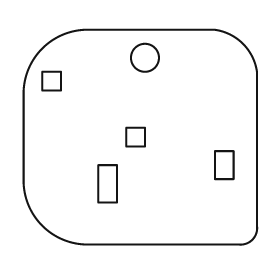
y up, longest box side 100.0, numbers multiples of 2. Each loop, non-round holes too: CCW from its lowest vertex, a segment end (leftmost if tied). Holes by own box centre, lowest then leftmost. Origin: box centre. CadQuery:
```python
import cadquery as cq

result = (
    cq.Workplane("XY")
    .moveTo(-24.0, -46.0)
    .lineTo(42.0, -46.0)
    .threePointArc((48.0, -44.0), (50.0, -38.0))
    .lineTo(50.0, 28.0)
    .threePointArc((44.0, 40.0), (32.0, 46.0))
    .lineTo(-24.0, 46.0)
    .threePointArc((-42.0, 38.0), (-50.0, 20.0))
    .lineTo(-50.0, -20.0)
    .threePointArc((-42.0, -38.0), (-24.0, -46.0))
    .close()
    .moveTo(-18.0, -28.0)
    .lineTo(-10.0, -28.0)
    .lineTo(-10.0, -12.0)
    .lineTo(-18.0, -12.0)
    .close()
    .moveTo(32.0, -18.0)
    .lineTo(40.0, -18.0)
    .lineTo(40.0, -6.0)
    .lineTo(32.0, -6.0)
    .close()
    .moveTo(-6.0, -4.0)
    .lineTo(2.0, -4.0)
    .lineTo(2.0, 4.0)
    .lineTo(-6.0, 4.0)
    .close()
    .moveTo(-42.0, 20.0)
    .lineTo(-34.0, 20.0)
    .lineTo(-34.0, 28.0)
    .lineTo(-42.0, 28.0)
    .close()
    .moveTo(2.0, 34.0)
    .circle(6.0)
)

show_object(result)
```